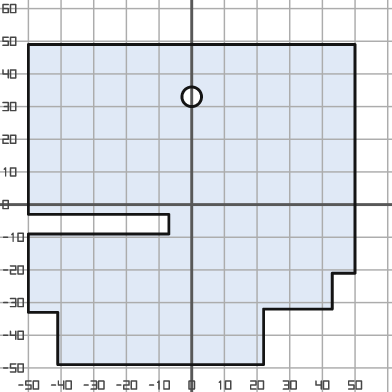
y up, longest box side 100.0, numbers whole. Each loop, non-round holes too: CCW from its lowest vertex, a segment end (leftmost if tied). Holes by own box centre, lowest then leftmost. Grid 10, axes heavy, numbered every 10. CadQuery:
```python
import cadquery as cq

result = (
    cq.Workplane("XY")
    .moveTo(-41.0, -49.0)
    .lineTo(22.0, -49.0)
    .lineTo(22.0, -32.0)
    .lineTo(43.0, -32.0)
    .lineTo(43.0, -21.0)
    .lineTo(50.0, -21.0)
    .lineTo(50.0, 49.0)
    .lineTo(-50.0, 49.0)
    .lineTo(-50.0, -3.0)
    .lineTo(-7.0, -3.0)
    .lineTo(-7.0, -9.0)
    .lineTo(-50.0, -9.0)
    .lineTo(-50.0, -33.0)
    .lineTo(-41.0, -33.0)
    .close()
    .moveTo(0.0, 33.0)
    .circle(3.0)
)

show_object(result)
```